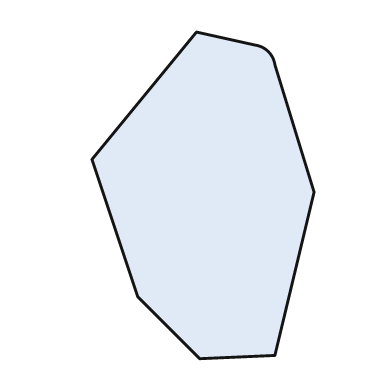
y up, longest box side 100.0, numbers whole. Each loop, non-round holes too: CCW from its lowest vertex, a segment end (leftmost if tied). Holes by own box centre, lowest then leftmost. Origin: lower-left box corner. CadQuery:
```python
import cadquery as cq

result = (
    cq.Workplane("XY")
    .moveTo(33.0, 0.0)
    .lineTo(56.0, 1.0)
    .lineTo(68.0, 51.0)
    .lineTo(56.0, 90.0)
    .threePointArc((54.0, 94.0), (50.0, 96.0))
    .lineTo(32.0, 100.0)
    .lineTo(0.0, 61.0)
    .lineTo(14.0, 19.0)
    .close()
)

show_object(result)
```